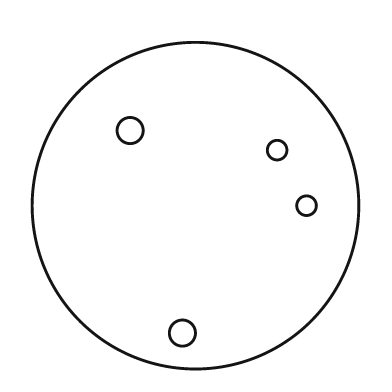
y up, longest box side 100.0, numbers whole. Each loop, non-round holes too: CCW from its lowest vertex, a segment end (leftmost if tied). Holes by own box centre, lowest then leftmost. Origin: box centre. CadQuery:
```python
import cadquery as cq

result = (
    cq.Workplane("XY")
    .moveTo(0.0, 0.0)
    .circle(50.0)
    .moveTo(-4.0, -39.0)
    .circle(4.0)
    .moveTo(34.0, 0.0)
    .circle(3.0)
    .moveTo(25.0, 17.0)
    .circle(3.0)
    .moveTo(-20.0, 23.0)
    .circle(4.0)
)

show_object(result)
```